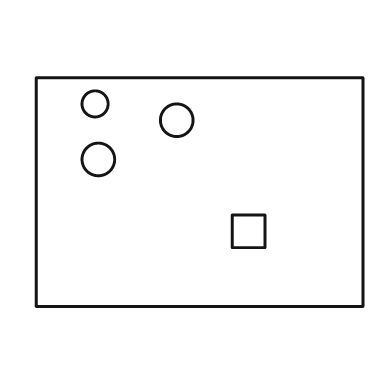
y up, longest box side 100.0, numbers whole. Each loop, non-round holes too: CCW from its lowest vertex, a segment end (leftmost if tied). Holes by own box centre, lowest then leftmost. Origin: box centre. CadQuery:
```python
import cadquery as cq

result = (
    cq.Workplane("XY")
    .moveTo(-50.0, -35.0)
    .lineTo(50.0, -35.0)
    .lineTo(50.0, 35.0)
    .lineTo(-50.0, 35.0)
    .close()
    .moveTo(10.0, -17.0)
    .lineTo(20.0, -17.0)
    .lineTo(20.0, -7.0)
    .lineTo(10.0, -7.0)
    .close()
    .moveTo(-31.0, 10.0)
    .circle(5.0)
    .moveTo(-7.0, 22.0)
    .circle(5.0)
    .moveTo(-32.0, 27.0)
    .circle(4.0)
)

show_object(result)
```